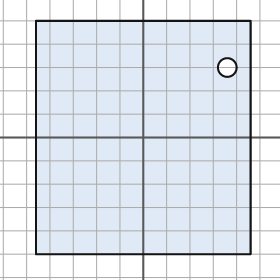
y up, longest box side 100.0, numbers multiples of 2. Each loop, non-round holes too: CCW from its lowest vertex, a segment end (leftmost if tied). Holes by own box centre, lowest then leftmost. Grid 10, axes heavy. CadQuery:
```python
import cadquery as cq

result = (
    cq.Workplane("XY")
    .moveTo(-46.0, -50.0)
    .lineTo(46.0, -50.0)
    .lineTo(46.0, 50.0)
    .lineTo(-46.0, 50.0)
    .close()
    .moveTo(36.0, 30.0)
    .circle(4.0)
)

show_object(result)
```